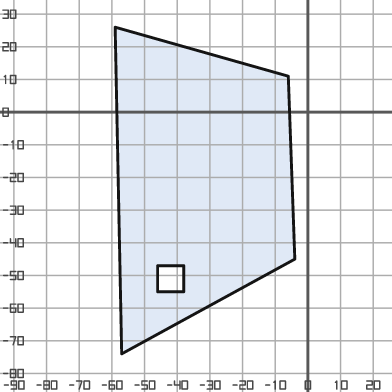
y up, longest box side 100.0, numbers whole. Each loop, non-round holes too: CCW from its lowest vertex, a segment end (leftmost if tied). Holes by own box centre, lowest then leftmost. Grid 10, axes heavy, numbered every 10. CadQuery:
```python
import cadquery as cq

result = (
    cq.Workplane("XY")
    .moveTo(-57.0, -74.0)
    .lineTo(-4.0, -45.0)
    .lineTo(-6.0, 11.0)
    .lineTo(-59.0, 26.0)
    .close()
    .moveTo(-46.0, -55.0)
    .lineTo(-38.0, -55.0)
    .lineTo(-38.0, -47.0)
    .lineTo(-46.0, -47.0)
    .close()
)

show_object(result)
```